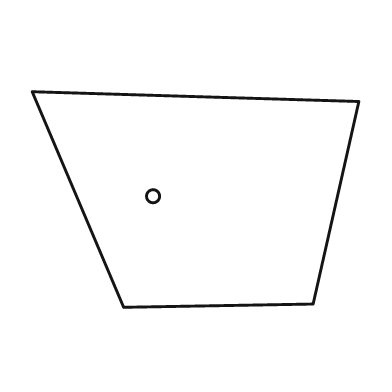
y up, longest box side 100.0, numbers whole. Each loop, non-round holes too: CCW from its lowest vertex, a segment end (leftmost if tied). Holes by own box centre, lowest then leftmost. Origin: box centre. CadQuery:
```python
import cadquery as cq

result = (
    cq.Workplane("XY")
    .moveTo(-22.0, -33.0)
    .lineTo(36.0, -32.0)
    .lineTo(50.0, 30.0)
    .lineTo(-50.0, 33.0)
    .close()
    .moveTo(-13.0, 1.0)
    .circle(2.0)
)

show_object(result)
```